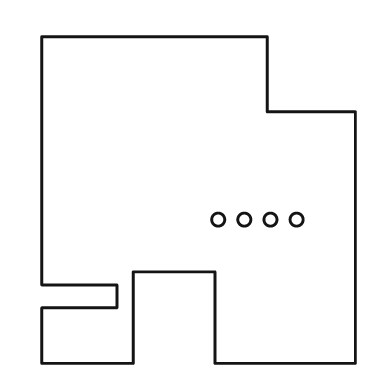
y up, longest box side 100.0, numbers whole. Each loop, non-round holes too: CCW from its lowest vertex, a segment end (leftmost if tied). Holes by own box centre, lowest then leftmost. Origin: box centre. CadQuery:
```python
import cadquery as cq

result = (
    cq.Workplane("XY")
    .moveTo(-48.0, -50.0)
    .lineTo(-20.0, -50.0)
    .lineTo(-20.0, -22.0)
    .lineTo(5.0, -22.0)
    .lineTo(5.0, -50.0)
    .lineTo(48.0, -50.0)
    .lineTo(48.0, 27.0)
    .lineTo(21.0, 27.0)
    .lineTo(21.0, 50.0)
    .lineTo(-48.0, 50.0)
    .lineTo(-48.0, -26.0)
    .lineTo(-25.0, -26.0)
    .lineTo(-25.0, -33.0)
    .lineTo(-48.0, -33.0)
    .close()
    .moveTo(6.0, -6.0)
    .circle(2.0)
    .moveTo(14.0, -6.0)
    .circle(2.0)
    .moveTo(22.0, -6.0)
    .circle(2.0)
    .moveTo(30.0, -6.0)
    .circle(2.0)
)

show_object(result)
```